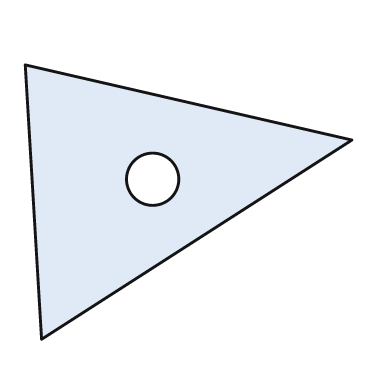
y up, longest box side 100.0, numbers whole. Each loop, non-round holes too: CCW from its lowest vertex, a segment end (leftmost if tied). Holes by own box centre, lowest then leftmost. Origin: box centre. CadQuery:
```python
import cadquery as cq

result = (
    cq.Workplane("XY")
    .moveTo(-45.0, -42.0)
    .lineTo(50.0, 19.0)
    .lineTo(-50.0, 42.0)
    .close()
    .moveTo(-11.0, 7.0)
    .circle(8.0)
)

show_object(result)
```